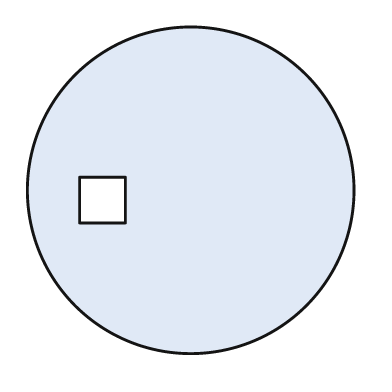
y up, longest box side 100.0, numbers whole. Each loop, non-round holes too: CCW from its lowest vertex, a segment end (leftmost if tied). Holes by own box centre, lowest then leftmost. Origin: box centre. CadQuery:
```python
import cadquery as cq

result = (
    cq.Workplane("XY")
    .moveTo(0.0, 0.0)
    .circle(50.0)
    .moveTo(-34.0, -10.0)
    .lineTo(-20.0, -10.0)
    .lineTo(-20.0, 4.0)
    .lineTo(-34.0, 4.0)
    .close()
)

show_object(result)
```